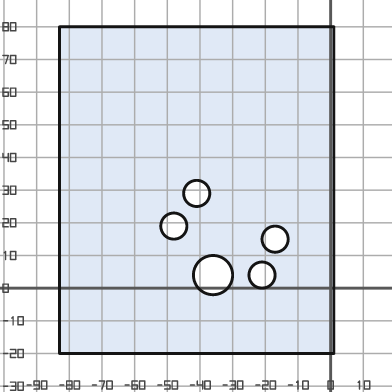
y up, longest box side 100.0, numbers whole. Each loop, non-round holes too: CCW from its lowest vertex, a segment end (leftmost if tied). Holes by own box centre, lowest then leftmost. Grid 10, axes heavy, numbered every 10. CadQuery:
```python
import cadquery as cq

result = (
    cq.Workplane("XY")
    .moveTo(-83.0, -20.0)
    .lineTo(1.0, -20.0)
    .lineTo(1.0, 80.0)
    .lineTo(-83.0, 80.0)
    .close()
    .moveTo(-36.0, 4.0)
    .circle(6.0)
    .moveTo(-21.0, 4.0)
    .circle(4.0)
    .moveTo(-17.0, 15.0)
    .circle(4.0)
    .moveTo(-48.0, 19.0)
    .circle(4.0)
    .moveTo(-41.0, 29.0)
    .circle(4.0)
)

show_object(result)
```